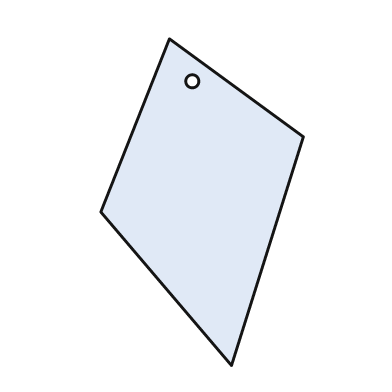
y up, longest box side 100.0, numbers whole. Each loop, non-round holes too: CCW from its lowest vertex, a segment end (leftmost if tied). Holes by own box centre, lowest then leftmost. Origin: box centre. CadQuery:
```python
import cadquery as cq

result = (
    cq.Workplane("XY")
    .moveTo(9.0, -50.0)
    .lineTo(31.0, 20.0)
    .lineTo(-10.0, 50.0)
    .lineTo(-31.0, -3.0)
    .close()
    .moveTo(-3.0, 37.0)
    .circle(2.0)
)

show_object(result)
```